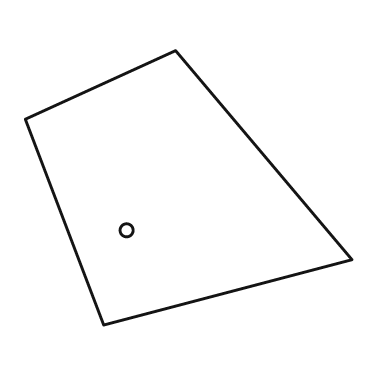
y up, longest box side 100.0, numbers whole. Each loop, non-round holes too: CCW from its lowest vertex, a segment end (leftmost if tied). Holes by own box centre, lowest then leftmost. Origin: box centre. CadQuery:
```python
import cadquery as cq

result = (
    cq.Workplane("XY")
    .moveTo(-26.0, -42.0)
    .lineTo(50.0, -22.0)
    .lineTo(-4.0, 42.0)
    .lineTo(-50.0, 21.0)
    .close()
    .moveTo(-19.0, -13.0)
    .circle(2.0)
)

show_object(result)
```